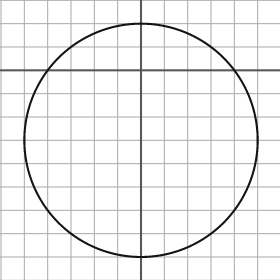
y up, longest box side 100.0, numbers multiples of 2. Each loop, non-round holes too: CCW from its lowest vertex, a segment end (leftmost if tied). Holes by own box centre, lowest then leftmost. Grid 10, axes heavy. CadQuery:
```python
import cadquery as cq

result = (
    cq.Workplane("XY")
    .moveTo(0.0, -30.0)
    .circle(50.0)
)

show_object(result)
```